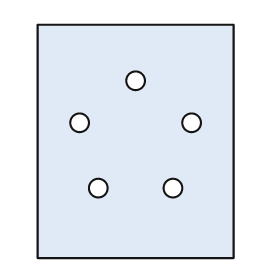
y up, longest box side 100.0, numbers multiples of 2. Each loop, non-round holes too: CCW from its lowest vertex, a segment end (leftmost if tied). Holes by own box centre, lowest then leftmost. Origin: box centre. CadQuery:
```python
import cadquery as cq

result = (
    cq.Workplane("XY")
    .moveTo(-42.0, -50.0)
    .lineTo(42.0, -50.0)
    .lineTo(42.0, 50.0)
    .lineTo(-42.0, 50.0)
    .close()
    .moveTo(-16.0, -20.0)
    .circle(4.0)
    .moveTo(16.0, -20.0)
    .circle(4.0)
    .moveTo(-24.0, 8.0)
    .circle(4.0)
    .moveTo(24.0, 8.0)
    .circle(4.0)
    .moveTo(0.0, 26.0)
    .circle(4.0)
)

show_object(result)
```